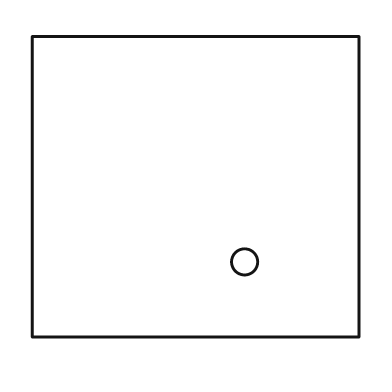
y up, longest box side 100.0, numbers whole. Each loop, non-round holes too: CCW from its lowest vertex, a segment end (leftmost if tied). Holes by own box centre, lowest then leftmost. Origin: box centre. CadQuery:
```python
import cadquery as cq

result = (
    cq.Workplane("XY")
    .moveTo(-50.0, -46.0)
    .lineTo(50.0, -46.0)
    .lineTo(50.0, 46.0)
    .lineTo(-50.0, 46.0)
    .close()
    .moveTo(15.0, -23.0)
    .circle(4.0)
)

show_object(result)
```